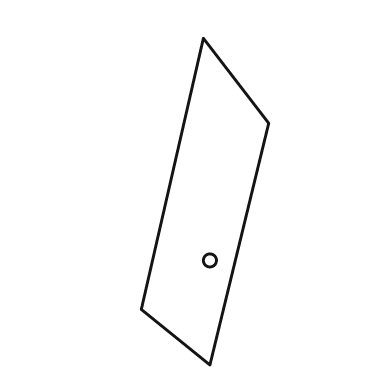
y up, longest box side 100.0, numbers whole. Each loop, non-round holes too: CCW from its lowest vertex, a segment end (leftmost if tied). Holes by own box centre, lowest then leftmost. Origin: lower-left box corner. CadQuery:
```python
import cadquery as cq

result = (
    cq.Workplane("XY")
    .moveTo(21.0, 0.0)
    .lineTo(39.0, 74.0)
    .lineTo(19.0, 100.0)
    .lineTo(0.0, 17.0)
    .close()
    .moveTo(21.0, 32.0)
    .circle(2.0)
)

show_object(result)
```